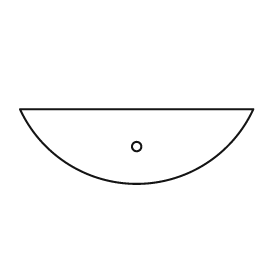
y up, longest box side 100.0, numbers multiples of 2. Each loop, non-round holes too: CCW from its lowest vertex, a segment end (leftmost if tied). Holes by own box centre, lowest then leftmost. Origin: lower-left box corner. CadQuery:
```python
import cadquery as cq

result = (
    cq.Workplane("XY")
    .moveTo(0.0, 32.0)
    .threePointArc((50.0, 0.0), (100.0, 32.0))
    .close()
    .moveTo(50.0, 16.0)
    .circle(2.0)
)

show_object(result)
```